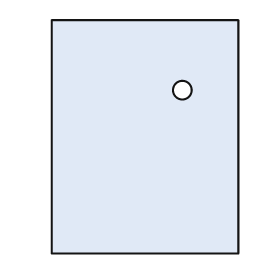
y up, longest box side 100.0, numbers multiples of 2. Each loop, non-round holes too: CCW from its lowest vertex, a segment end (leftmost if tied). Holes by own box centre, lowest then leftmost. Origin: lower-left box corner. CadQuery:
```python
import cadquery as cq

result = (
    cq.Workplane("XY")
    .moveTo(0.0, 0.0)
    .lineTo(80.0, 0.0)
    .lineTo(80.0, 100.0)
    .lineTo(0.0, 100.0)
    .close()
    .moveTo(56.0, 70.0)
    .circle(4.0)
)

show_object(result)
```